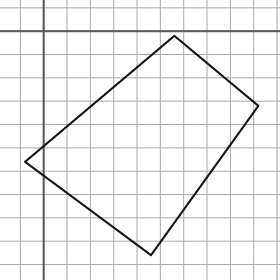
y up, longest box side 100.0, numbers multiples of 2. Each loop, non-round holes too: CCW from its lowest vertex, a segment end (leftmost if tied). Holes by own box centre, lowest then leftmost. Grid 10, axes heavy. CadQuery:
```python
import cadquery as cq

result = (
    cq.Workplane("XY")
    .moveTo(46.0, -96.0)
    .lineTo(92.0, -32.0)
    .lineTo(56.0, -2.0)
    .lineTo(-8.0, -56.0)
    .close()
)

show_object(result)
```